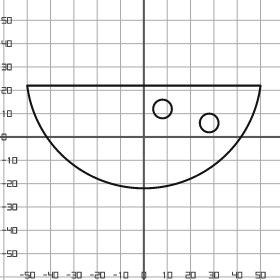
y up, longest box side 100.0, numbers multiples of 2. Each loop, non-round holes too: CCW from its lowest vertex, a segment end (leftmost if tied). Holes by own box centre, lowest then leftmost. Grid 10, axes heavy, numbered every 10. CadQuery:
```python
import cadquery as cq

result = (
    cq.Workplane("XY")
    .moveTo(-50.0, 22.0)
    .threePointArc((0.0, -22.0), (50.0, 22.0))
    .close()
    .moveTo(28.0, 6.0)
    .circle(4.0)
    .moveTo(8.0, 12.0)
    .circle(4.0)
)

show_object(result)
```